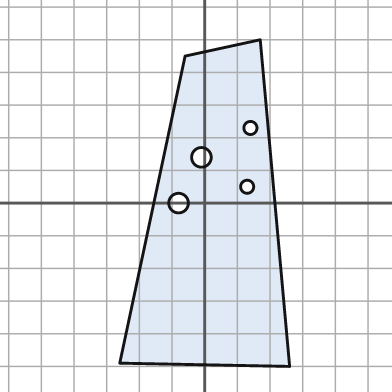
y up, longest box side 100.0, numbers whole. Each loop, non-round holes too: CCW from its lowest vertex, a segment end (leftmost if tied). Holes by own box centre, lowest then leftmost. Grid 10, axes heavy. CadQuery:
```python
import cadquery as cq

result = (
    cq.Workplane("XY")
    .moveTo(26.0, -50.0)
    .lineTo(17.0, 50.0)
    .lineTo(-6.0, 45.0)
    .lineTo(-26.0, -49.0)
    .close()
    .moveTo(-8.0, 0.0)
    .circle(3.0)
    .moveTo(13.0, 5.0)
    .circle(2.0)
    .moveTo(-1.0, 14.0)
    .circle(3.0)
    .moveTo(14.0, 23.0)
    .circle(2.0)
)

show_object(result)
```